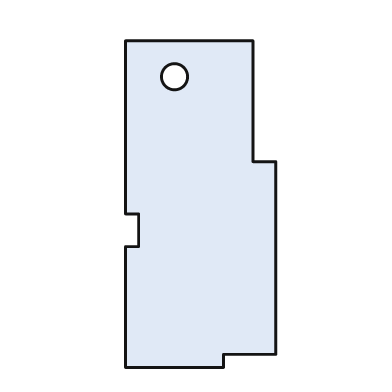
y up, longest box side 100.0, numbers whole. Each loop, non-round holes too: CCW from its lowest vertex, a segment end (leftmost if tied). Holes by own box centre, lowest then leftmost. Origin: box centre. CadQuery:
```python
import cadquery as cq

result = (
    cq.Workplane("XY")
    .moveTo(-23.0, -50.0)
    .lineTo(7.0, -50.0)
    .lineTo(7.0, -46.0)
    .lineTo(23.0, -46.0)
    .lineTo(23.0, 13.0)
    .lineTo(16.0, 13.0)
    .lineTo(16.0, 50.0)
    .lineTo(-23.0, 50.0)
    .lineTo(-23.0, -3.0)
    .lineTo(-19.0, -3.0)
    .lineTo(-19.0, -13.0)
    .lineTo(-23.0, -13.0)
    .close()
    .moveTo(-8.0, 39.0)
    .circle(4.0)
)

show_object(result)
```